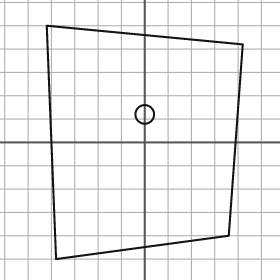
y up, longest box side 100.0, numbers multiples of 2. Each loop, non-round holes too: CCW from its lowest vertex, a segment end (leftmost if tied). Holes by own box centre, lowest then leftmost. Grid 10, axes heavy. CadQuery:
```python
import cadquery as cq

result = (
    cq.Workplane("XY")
    .moveTo(-38.0, -50.0)
    .lineTo(36.0, -40.0)
    .lineTo(42.0, 42.0)
    .lineTo(-42.0, 50.0)
    .close()
    .moveTo(0.0, 12.0)
    .circle(4.0)
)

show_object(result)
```